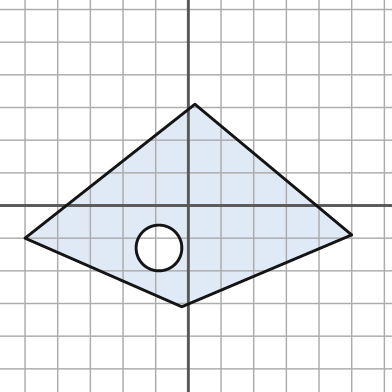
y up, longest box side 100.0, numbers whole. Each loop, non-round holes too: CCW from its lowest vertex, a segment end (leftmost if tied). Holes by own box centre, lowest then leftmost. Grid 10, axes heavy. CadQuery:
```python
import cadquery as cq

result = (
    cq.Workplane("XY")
    .moveTo(-2.0, -31.0)
    .lineTo(50.0, -9.0)
    .lineTo(2.0, 31.0)
    .lineTo(-50.0, -10.0)
    .close()
    .moveTo(-9.0, -13.0)
    .circle(7.0)
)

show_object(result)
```